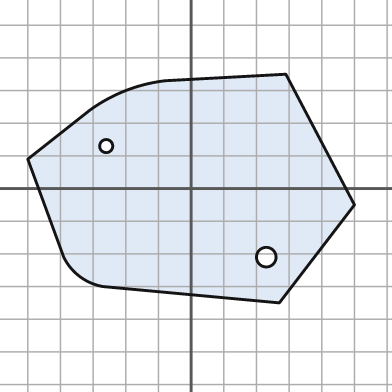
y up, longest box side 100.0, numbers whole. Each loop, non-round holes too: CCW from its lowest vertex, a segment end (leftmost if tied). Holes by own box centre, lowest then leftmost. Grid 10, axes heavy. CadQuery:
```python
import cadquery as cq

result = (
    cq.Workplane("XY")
    .moveTo(27.0, -35.0)
    .lineTo(50.0, -5.0)
    .lineTo(29.0, 35.0)
    .lineTo(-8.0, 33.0)
    .threePointArc((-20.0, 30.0), (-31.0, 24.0))
    .lineTo(-50.0, 9.0)
    .lineTo(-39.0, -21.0)
    .threePointArc((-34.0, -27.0), (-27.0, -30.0))
    .close()
    .moveTo(23.0, -21.0)
    .circle(3.0)
    .moveTo(-26.0, 13.0)
    .circle(2.0)
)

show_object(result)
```